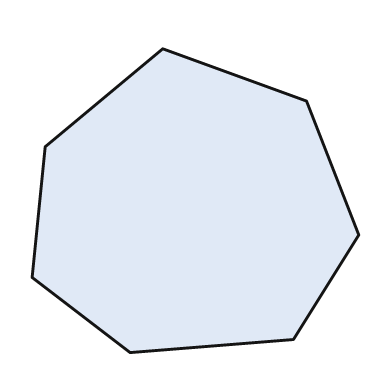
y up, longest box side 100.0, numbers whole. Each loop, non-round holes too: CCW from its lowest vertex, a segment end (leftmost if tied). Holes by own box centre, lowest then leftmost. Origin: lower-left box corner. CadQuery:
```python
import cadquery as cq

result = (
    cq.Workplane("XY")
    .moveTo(30.0, 0.0)
    .lineTo(80.0, 4.0)
    .lineTo(100.0, 36.0)
    .lineTo(84.0, 77.0)
    .lineTo(40.0, 93.0)
    .lineTo(4.0, 63.0)
    .lineTo(0.0, 23.0)
    .close()
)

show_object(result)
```